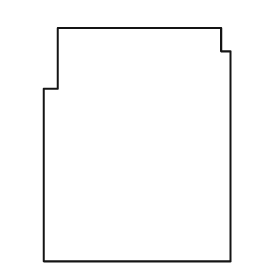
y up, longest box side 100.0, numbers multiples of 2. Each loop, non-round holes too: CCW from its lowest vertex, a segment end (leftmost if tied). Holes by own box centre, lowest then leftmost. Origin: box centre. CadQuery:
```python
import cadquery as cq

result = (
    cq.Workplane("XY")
    .moveTo(-40.0, -50.0)
    .lineTo(40.0, -50.0)
    .lineTo(40.0, 40.0)
    .lineTo(36.0, 40.0)
    .lineTo(36.0, 50.0)
    .lineTo(-34.0, 50.0)
    .lineTo(-34.0, 24.0)
    .lineTo(-40.0, 24.0)
    .close()
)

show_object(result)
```